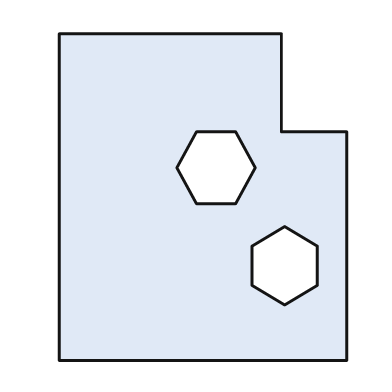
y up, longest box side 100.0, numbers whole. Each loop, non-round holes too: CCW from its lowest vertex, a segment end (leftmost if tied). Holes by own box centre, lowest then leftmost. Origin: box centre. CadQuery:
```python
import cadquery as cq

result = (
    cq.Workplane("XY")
    .moveTo(-44.0, -50.0)
    .lineTo(44.0, -50.0)
    .lineTo(44.0, 20.0)
    .lineTo(24.0, 20.0)
    .lineTo(24.0, 50.0)
    .lineTo(-44.0, 50.0)
    .close()
    .moveTo(25.0, -33.0)
    .lineTo(35.0, -27.0)
    .lineTo(35.0, -15.0)
    .lineTo(25.0, -9.0)
    .lineTo(15.0, -15.0)
    .lineTo(15.0, -27.0)
    .close()
    .moveTo(-2.0, -2.0)
    .lineTo(10.0, -2.0)
    .lineTo(16.0, 9.0)
    .lineTo(10.0, 20.0)
    .lineTo(-2.0, 20.0)
    .lineTo(-8.0, 9.0)
    .close()
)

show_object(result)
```